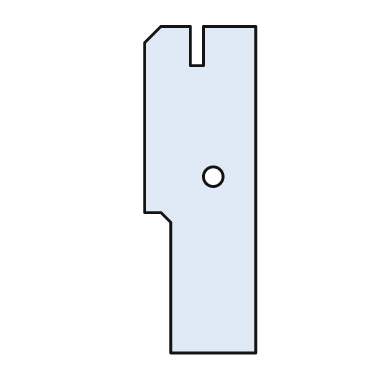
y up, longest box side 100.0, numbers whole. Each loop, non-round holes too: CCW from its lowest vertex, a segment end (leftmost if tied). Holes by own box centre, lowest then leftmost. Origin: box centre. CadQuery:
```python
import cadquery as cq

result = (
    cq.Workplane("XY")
    .moveTo(-9.0, -50.0)
    .lineTo(17.0, -50.0)
    .lineTo(17.0, 50.0)
    .lineTo(1.0, 50.0)
    .lineTo(1.0, 38.0)
    .lineTo(-3.0, 38.0)
    .lineTo(-3.0, 50.0)
    .lineTo(-12.0, 50.0)
    .lineTo(-17.0, 45.0)
    .lineTo(-17.0, -7.0)
    .lineTo(-12.0, -7.0)
    .lineTo(-9.0, -10.0)
    .close()
    .moveTo(4.0, 4.0)
    .circle(3.0)
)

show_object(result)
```